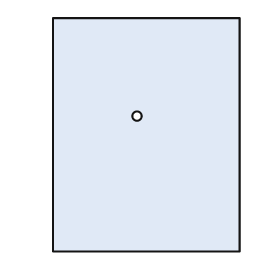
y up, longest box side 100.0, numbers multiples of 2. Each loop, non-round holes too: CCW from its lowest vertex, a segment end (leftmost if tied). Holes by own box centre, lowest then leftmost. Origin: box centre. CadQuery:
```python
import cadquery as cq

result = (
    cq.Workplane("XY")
    .moveTo(-40.0, -50.0)
    .lineTo(40.0, -50.0)
    .lineTo(40.0, 50.0)
    .lineTo(-40.0, 50.0)
    .close()
    .moveTo(-4.0, 8.0)
    .circle(2.0)
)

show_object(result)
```